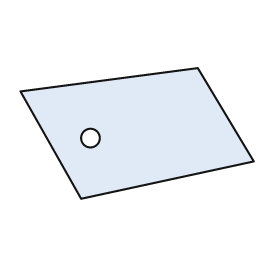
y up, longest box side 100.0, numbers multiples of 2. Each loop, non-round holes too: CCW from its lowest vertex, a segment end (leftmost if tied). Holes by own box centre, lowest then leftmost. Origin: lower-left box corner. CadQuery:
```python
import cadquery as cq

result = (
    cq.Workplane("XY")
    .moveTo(26.0, 0.0)
    .lineTo(100.0, 16.0)
    .lineTo(76.0, 56.0)
    .lineTo(0.0, 46.0)
    .close()
    .moveTo(30.0, 26.0)
    .circle(4.0)
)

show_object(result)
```